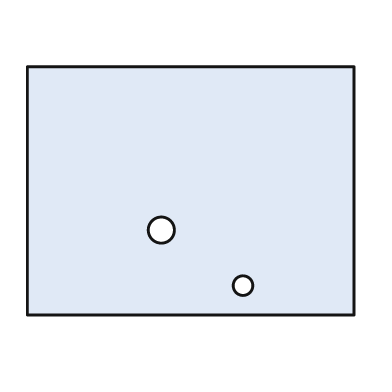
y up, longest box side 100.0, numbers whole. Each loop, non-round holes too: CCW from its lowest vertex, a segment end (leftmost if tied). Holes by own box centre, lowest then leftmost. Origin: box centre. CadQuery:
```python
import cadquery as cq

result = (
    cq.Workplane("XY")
    .moveTo(-50.0, -38.0)
    .lineTo(50.0, -38.0)
    .lineTo(50.0, 38.0)
    .lineTo(-50.0, 38.0)
    .close()
    .moveTo(16.0, -29.0)
    .circle(3.0)
    .moveTo(-9.0, -12.0)
    .circle(4.0)
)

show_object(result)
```